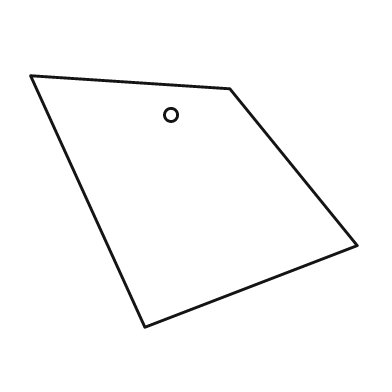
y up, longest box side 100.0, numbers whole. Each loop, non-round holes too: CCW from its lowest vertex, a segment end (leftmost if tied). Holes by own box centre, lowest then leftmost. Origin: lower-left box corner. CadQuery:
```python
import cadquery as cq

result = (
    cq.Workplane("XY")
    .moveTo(35.0, 0.0)
    .lineTo(100.0, 25.0)
    .lineTo(61.0, 73.0)
    .lineTo(0.0, 77.0)
    .close()
    .moveTo(43.0, 65.0)
    .circle(2.0)
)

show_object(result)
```